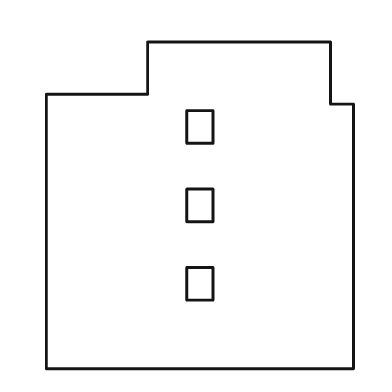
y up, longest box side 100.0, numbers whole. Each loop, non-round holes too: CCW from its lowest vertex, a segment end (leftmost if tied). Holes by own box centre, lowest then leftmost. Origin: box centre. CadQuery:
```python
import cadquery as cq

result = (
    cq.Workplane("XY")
    .moveTo(-47.0, -50.0)
    .lineTo(47.0, -50.0)
    .lineTo(47.0, 31.0)
    .lineTo(40.0, 31.0)
    .lineTo(40.0, 50.0)
    .lineTo(-16.0, 50.0)
    .lineTo(-16.0, 34.0)
    .lineTo(-47.0, 34.0)
    .close()
    .moveTo(-4.0, -29.0)
    .lineTo(4.0, -29.0)
    .lineTo(4.0, -19.0)
    .lineTo(-4.0, -19.0)
    .close()
    .moveTo(-4.0, -5.0)
    .lineTo(4.0, -5.0)
    .lineTo(4.0, 5.0)
    .lineTo(-4.0, 5.0)
    .close()
    .moveTo(-4.0, 19.0)
    .lineTo(4.0, 19.0)
    .lineTo(4.0, 29.0)
    .lineTo(-4.0, 29.0)
    .close()
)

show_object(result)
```